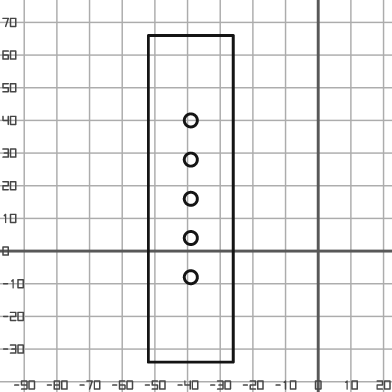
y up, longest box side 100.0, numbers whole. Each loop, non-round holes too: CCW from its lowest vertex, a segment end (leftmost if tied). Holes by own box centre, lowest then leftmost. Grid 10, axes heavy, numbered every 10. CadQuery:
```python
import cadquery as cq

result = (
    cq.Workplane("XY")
    .moveTo(-52.0, -34.0)
    .lineTo(-26.0, -34.0)
    .lineTo(-26.0, 66.0)
    .lineTo(-52.0, 66.0)
    .close()
    .moveTo(-39.0, -8.0)
    .circle(2.0)
    .moveTo(-39.0, 4.0)
    .circle(2.0)
    .moveTo(-39.0, 16.0)
    .circle(2.0)
    .moveTo(-39.0, 28.0)
    .circle(2.0)
    .moveTo(-39.0, 40.0)
    .circle(2.0)
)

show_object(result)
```